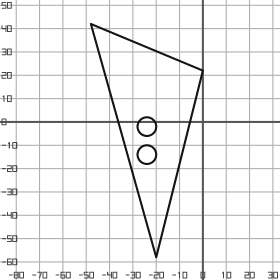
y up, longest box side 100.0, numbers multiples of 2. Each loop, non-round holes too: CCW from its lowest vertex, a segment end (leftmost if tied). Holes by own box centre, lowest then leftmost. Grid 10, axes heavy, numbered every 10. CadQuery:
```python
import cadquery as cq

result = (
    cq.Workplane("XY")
    .moveTo(-20.0, -58.0)
    .lineTo(0.0, 22.0)
    .lineTo(-48.0, 42.0)
    .close()
    .moveTo(-24.0, -14.0)
    .circle(4.0)
    .moveTo(-24.0, -2.0)
    .circle(4.0)
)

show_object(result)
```